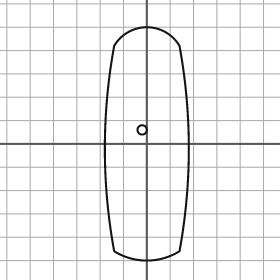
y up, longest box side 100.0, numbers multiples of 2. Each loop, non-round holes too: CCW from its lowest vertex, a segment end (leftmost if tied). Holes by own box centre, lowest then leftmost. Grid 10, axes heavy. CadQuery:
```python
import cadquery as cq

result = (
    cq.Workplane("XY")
    .moveTo(-14.0, -46.0)
    .threePointArc((0.0, -50.0), (14.0, -46.0))
    .threePointArc((18.0, -2.0), (14.0, 42.0))
    .threePointArc((0.0, 50.0), (-14.0, 42.0))
    .threePointArc((-18.0, -2.0), (-14.0, -46.0))
    .close()
    .moveTo(-2.0, 6.0)
    .circle(2.0)
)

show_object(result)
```